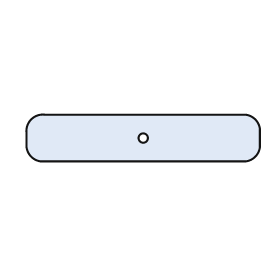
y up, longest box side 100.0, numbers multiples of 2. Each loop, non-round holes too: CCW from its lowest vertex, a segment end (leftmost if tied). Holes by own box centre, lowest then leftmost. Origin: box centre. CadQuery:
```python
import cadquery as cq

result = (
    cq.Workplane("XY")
    .moveTo(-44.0, -10.0)
    .lineTo(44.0, -10.0)
    .threePointArc((48.0, -8.0), (50.0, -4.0))
    .lineTo(50.0, 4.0)
    .threePointArc((48.0, 8.0), (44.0, 10.0))
    .lineTo(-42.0, 10.0)
    .threePointArc((-48.0, 8.0), (-50.0, 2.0))
    .lineTo(-50.0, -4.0)
    .threePointArc((-48.0, -8.0), (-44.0, -10.0))
    .close()
    .moveTo(0.0, 0.0)
    .circle(2.0)
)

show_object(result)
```